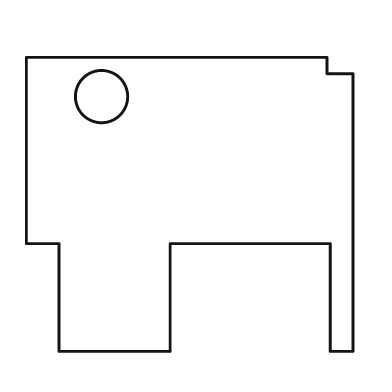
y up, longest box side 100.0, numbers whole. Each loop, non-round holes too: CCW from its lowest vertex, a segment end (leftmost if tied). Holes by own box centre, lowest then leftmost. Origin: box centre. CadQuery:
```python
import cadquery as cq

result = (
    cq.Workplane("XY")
    .moveTo(-40.0, -45.0)
    .lineTo(-6.0, -45.0)
    .lineTo(-6.0, -12.0)
    .lineTo(43.0, -12.0)
    .lineTo(43.0, -45.0)
    .lineTo(50.0, -45.0)
    .lineTo(50.0, 40.0)
    .lineTo(42.0, 40.0)
    .lineTo(42.0, 45.0)
    .lineTo(-50.0, 45.0)
    .lineTo(-50.0, -12.0)
    .lineTo(-40.0, -12.0)
    .close()
    .moveTo(-27.0, 33.0)
    .circle(8.0)
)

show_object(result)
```